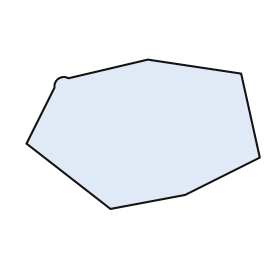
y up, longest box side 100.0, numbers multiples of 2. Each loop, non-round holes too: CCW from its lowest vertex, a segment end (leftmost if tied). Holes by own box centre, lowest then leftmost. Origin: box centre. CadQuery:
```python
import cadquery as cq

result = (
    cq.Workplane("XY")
    .moveTo(-14.0, -32.0)
    .lineTo(18.0, -26.0)
    .lineTo(50.0, -10.0)
    .lineTo(42.0, 26.0)
    .lineTo(2.0, 32.0)
    .lineTo(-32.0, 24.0)
    .threePointArc((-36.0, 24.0), (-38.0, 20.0))
    .lineTo(-50.0, -4.0)
    .close()
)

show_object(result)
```